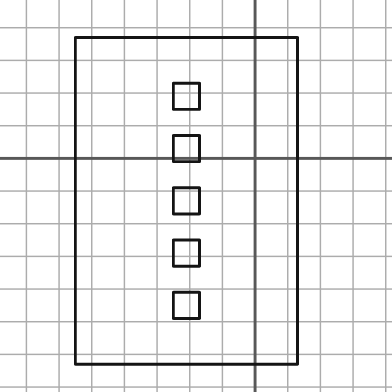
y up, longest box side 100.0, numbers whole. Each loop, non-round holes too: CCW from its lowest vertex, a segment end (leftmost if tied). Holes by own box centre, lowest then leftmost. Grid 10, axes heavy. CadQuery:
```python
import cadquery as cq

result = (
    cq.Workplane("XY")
    .moveTo(-55.0, -63.0)
    .lineTo(13.0, -63.0)
    .lineTo(13.0, 37.0)
    .lineTo(-55.0, 37.0)
    .close()
    .moveTo(-25.0, -49.0)
    .lineTo(-17.0, -49.0)
    .lineTo(-17.0, -41.0)
    .lineTo(-25.0, -41.0)
    .close()
    .moveTo(-25.0, -33.0)
    .lineTo(-17.0, -33.0)
    .lineTo(-17.0, -25.0)
    .lineTo(-25.0, -25.0)
    .close()
    .moveTo(-25.0, -17.0)
    .lineTo(-17.0, -17.0)
    .lineTo(-17.0, -9.0)
    .lineTo(-25.0, -9.0)
    .close()
    .moveTo(-25.0, -1.0)
    .lineTo(-17.0, -1.0)
    .lineTo(-17.0, 7.0)
    .lineTo(-25.0, 7.0)
    .close()
    .moveTo(-25.0, 15.0)
    .lineTo(-17.0, 15.0)
    .lineTo(-17.0, 23.0)
    .lineTo(-25.0, 23.0)
    .close()
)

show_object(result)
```